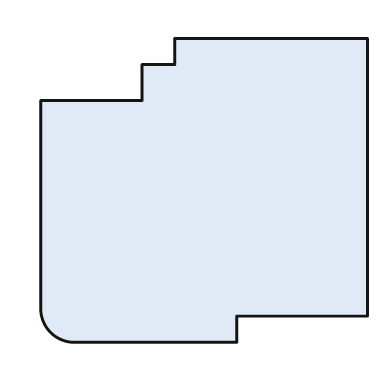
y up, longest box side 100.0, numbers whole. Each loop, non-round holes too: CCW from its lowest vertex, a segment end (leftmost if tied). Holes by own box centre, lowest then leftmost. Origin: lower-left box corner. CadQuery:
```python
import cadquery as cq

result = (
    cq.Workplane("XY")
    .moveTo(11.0, 0.0)
    .lineTo(60.0, 0.0)
    .lineTo(60.0, 8.0)
    .lineTo(100.0, 8.0)
    .lineTo(100.0, 93.0)
    .lineTo(41.0, 93.0)
    .lineTo(41.0, 85.0)
    .lineTo(31.0, 85.0)
    .lineTo(31.0, 74.0)
    .lineTo(0.0, 74.0)
    .lineTo(0.0, 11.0)
    .threePointArc((3.0, 3.0), (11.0, 0.0))
    .close()
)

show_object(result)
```